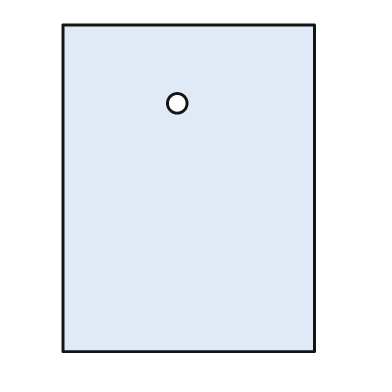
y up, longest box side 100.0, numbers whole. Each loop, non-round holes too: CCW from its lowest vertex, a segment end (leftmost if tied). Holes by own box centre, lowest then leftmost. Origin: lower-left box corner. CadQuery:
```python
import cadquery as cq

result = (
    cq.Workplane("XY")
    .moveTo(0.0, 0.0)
    .lineTo(77.0, 0.0)
    .lineTo(77.0, 100.0)
    .lineTo(0.0, 100.0)
    .close()
    .moveTo(35.0, 76.0)
    .circle(3.0)
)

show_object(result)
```